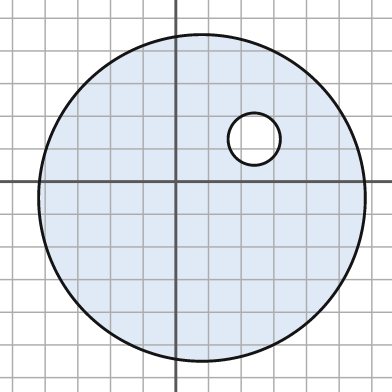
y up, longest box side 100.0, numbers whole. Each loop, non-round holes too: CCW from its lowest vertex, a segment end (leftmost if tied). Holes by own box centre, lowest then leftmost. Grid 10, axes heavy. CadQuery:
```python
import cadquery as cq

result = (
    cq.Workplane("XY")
    .moveTo(8.0, -5.0)
    .circle(50.0)
    .moveTo(24.0, 13.0)
    .circle(8.0)
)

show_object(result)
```